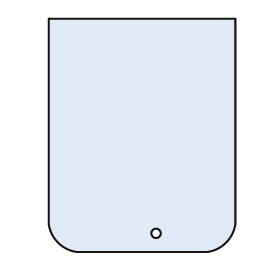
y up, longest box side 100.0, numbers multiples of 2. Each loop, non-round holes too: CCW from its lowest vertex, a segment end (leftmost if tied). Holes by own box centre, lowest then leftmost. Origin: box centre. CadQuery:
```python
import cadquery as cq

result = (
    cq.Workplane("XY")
    .moveTo(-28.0, -50.0)
    .lineTo(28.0, -50.0)
    .threePointArc((36.0, -46.0), (40.0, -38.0))
    .lineTo(40.0, 50.0)
    .lineTo(-40.0, 50.0)
    .lineTo(-40.0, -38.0)
    .threePointArc((-36.0, -46.0), (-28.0, -50.0))
    .close()
    .moveTo(6.0, -42.0)
    .circle(2.0)
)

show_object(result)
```